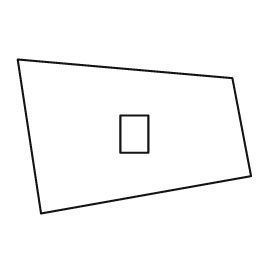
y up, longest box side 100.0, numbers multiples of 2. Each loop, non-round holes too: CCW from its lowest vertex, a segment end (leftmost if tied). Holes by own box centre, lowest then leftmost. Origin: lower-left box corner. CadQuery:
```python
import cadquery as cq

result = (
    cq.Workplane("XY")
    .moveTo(10.0, 0.0)
    .lineTo(100.0, 16.0)
    .lineTo(92.0, 58.0)
    .lineTo(0.0, 66.0)
    .close()
    .moveTo(44.0, 26.0)
    .lineTo(56.0, 26.0)
    .lineTo(56.0, 42.0)
    .lineTo(44.0, 42.0)
    .close()
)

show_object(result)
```